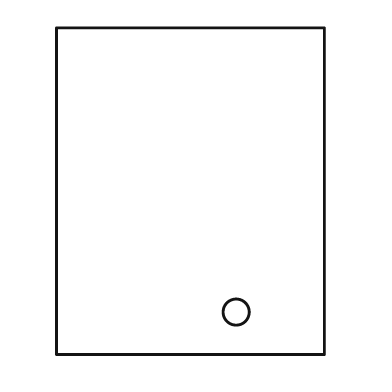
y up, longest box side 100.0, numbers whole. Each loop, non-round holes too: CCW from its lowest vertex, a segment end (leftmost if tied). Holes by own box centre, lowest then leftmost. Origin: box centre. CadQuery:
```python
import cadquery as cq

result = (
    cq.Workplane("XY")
    .moveTo(-41.0, -50.0)
    .lineTo(41.0, -50.0)
    .lineTo(41.0, 50.0)
    .lineTo(-41.0, 50.0)
    .close()
    .moveTo(14.0, -37.0)
    .circle(4.0)
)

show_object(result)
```